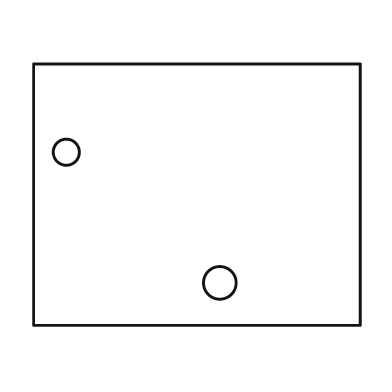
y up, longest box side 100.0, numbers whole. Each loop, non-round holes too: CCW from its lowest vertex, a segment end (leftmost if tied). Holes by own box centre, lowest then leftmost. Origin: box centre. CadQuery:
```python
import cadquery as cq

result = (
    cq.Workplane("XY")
    .moveTo(-50.0, -40.0)
    .lineTo(50.0, -40.0)
    .lineTo(50.0, 40.0)
    .lineTo(-50.0, 40.0)
    .close()
    .moveTo(7.0, -27.0)
    .circle(5.0)
    .moveTo(-40.0, 13.0)
    .circle(4.0)
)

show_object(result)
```